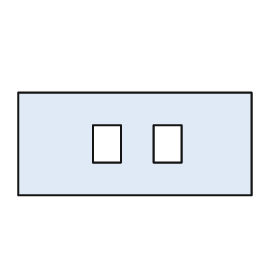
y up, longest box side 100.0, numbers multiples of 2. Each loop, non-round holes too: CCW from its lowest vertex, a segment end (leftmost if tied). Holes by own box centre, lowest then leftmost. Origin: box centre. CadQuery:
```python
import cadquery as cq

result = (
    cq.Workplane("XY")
    .moveTo(-50.0, -22.0)
    .lineTo(50.0, -22.0)
    .lineTo(50.0, 22.0)
    .lineTo(-50.0, 22.0)
    .close()
    .moveTo(-18.0, -8.0)
    .lineTo(-6.0, -8.0)
    .lineTo(-6.0, 8.0)
    .lineTo(-18.0, 8.0)
    .close()
    .moveTo(8.0, -8.0)
    .lineTo(20.0, -8.0)
    .lineTo(20.0, 8.0)
    .lineTo(8.0, 8.0)
    .close()
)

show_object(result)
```